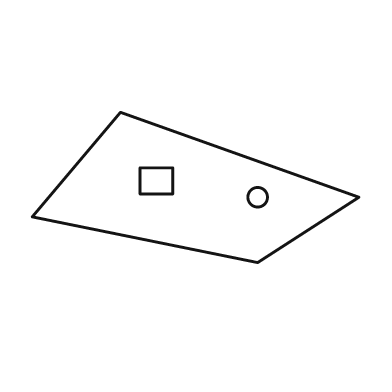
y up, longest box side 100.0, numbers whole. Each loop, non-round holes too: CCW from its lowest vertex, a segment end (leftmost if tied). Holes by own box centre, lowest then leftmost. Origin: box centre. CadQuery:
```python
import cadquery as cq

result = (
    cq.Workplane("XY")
    .moveTo(19.0, -23.0)
    .lineTo(50.0, -3.0)
    .lineTo(-23.0, 23.0)
    .lineTo(-50.0, -9.0)
    .close()
    .moveTo(19.0, -3.0)
    .circle(3.0)
    .moveTo(-17.0, -2.0)
    .lineTo(-7.0, -2.0)
    .lineTo(-7.0, 6.0)
    .lineTo(-17.0, 6.0)
    .close()
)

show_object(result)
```